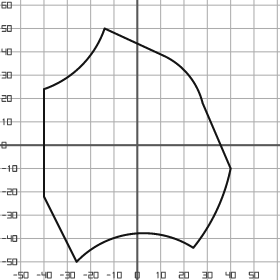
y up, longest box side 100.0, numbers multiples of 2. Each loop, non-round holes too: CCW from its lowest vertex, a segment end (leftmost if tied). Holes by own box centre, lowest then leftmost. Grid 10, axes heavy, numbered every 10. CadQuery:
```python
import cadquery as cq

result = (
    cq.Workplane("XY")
    .moveTo(-26.0, -50.0)
    .threePointArc((-2.0, -38.0), (24.0, -44.0))
    .threePointArc((34.0, -28.0), (40.0, -10.0))
    .lineTo(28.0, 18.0)
    .threePointArc((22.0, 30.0), (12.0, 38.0))
    .lineTo(-14.0, 50.0)
    .threePointArc((-24.0, 34.0), (-40.0, 24.0))
    .lineTo(-40.0, -22.0)
    .close()
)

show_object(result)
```